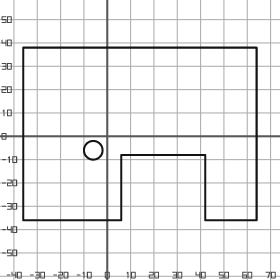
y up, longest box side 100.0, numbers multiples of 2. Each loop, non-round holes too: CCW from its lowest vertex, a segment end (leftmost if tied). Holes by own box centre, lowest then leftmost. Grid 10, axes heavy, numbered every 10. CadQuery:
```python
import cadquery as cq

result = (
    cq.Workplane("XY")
    .moveTo(-36.0, -36.0)
    .lineTo(6.0, -36.0)
    .lineTo(6.0, -8.0)
    .lineTo(42.0, -8.0)
    .lineTo(42.0, -36.0)
    .lineTo(64.0, -36.0)
    .lineTo(64.0, 38.0)
    .lineTo(-36.0, 38.0)
    .close()
    .moveTo(-6.0, -6.0)
    .circle(4.0)
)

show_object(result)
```